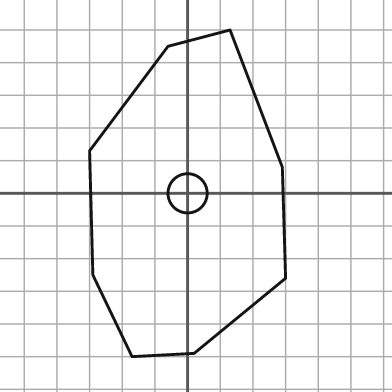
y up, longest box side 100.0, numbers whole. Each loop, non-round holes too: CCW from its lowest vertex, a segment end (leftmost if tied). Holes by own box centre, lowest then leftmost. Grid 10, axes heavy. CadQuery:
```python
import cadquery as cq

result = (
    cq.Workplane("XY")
    .moveTo(-17.0, -50.0)
    .lineTo(2.0, -49.0)
    .lineTo(30.0, -26.0)
    .lineTo(29.0, 8.0)
    .lineTo(13.0, 50.0)
    .lineTo(-6.0, 45.0)
    .lineTo(-30.0, 13.0)
    .lineTo(-29.0, -25.0)
    .close()
    .moveTo(0.0, 0.0)
    .circle(6.0)
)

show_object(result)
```